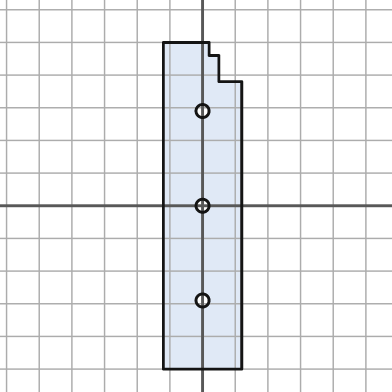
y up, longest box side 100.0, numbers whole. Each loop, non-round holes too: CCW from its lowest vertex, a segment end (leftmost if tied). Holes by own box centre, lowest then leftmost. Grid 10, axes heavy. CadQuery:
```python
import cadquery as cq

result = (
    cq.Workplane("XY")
    .moveTo(-12.0, -50.0)
    .lineTo(12.0, -50.0)
    .lineTo(12.0, 38.0)
    .lineTo(5.0, 38.0)
    .lineTo(5.0, 46.0)
    .lineTo(2.0, 46.0)
    .lineTo(2.0, 50.0)
    .lineTo(-12.0, 50.0)
    .close()
    .moveTo(0.0, -29.0)
    .circle(2.0)
    .moveTo(0.0, 0.0)
    .circle(2.0)
    .moveTo(0.0, 29.0)
    .circle(2.0)
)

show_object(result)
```